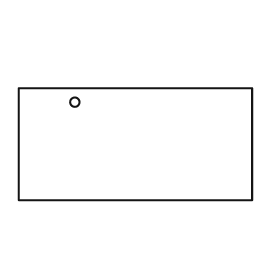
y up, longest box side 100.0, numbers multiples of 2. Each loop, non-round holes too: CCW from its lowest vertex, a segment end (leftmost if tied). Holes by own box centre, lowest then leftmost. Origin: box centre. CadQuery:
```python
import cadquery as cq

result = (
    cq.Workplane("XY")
    .moveTo(-50.0, -24.0)
    .lineTo(50.0, -24.0)
    .lineTo(50.0, 24.0)
    .lineTo(-50.0, 24.0)
    .close()
    .moveTo(-26.0, 18.0)
    .circle(2.0)
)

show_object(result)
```